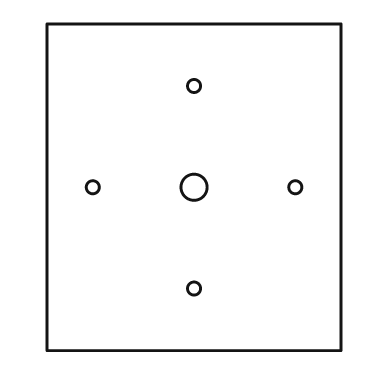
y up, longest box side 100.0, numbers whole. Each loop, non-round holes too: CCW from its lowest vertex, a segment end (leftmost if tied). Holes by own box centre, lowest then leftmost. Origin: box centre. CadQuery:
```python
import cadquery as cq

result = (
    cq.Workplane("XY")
    .moveTo(-45.0, -50.0)
    .lineTo(45.0, -50.0)
    .lineTo(45.0, 50.0)
    .lineTo(-45.0, 50.0)
    .close()
    .moveTo(0.0, -31.0)
    .circle(2.0)
    .moveTo(-31.0, 0.0)
    .circle(2.0)
    .moveTo(0.0, 0.0)
    .circle(4.0)
    .moveTo(31.0, 0.0)
    .circle(2.0)
    .moveTo(0.0, 31.0)
    .circle(2.0)
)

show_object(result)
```